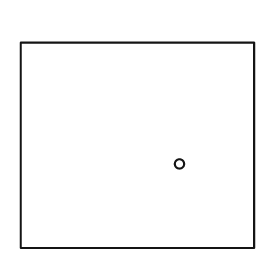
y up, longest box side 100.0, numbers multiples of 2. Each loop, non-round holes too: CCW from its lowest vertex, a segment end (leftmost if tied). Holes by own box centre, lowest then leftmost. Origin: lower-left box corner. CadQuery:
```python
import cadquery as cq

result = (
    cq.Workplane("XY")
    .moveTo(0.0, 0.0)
    .lineTo(100.0, 0.0)
    .lineTo(100.0, 88.0)
    .lineTo(0.0, 88.0)
    .close()
    .moveTo(68.0, 36.0)
    .circle(2.0)
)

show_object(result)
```